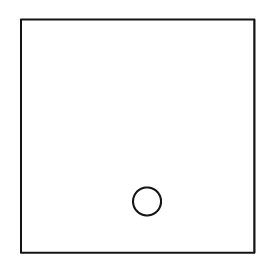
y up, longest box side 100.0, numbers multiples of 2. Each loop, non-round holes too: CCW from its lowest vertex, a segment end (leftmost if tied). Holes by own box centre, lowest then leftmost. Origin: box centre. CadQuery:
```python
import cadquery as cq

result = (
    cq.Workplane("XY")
    .moveTo(-50.0, -50.0)
    .lineTo(50.0, -50.0)
    .lineTo(50.0, 50.0)
    .lineTo(-50.0, 50.0)
    .close()
    .moveTo(4.0, -28.0)
    .circle(6.0)
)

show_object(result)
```